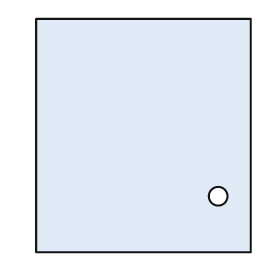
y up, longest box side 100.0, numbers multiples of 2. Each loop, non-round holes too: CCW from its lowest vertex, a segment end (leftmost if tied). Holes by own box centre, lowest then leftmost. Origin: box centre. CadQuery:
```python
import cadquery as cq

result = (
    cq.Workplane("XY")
    .moveTo(-46.0, -50.0)
    .lineTo(46.0, -50.0)
    .lineTo(46.0, 50.0)
    .lineTo(-46.0, 50.0)
    .close()
    .moveTo(32.0, -26.0)
    .circle(4.0)
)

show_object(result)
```